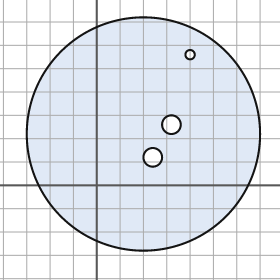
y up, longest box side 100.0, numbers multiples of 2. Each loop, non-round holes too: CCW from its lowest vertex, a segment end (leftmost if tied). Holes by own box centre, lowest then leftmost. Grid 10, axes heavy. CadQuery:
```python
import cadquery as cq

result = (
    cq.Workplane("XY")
    .moveTo(20.0, 22.0)
    .circle(50.0)
    .moveTo(24.0, 12.0)
    .circle(4.0)
    .moveTo(32.0, 26.0)
    .circle(4.0)
    .moveTo(40.0, 56.0)
    .circle(2.0)
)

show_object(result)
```